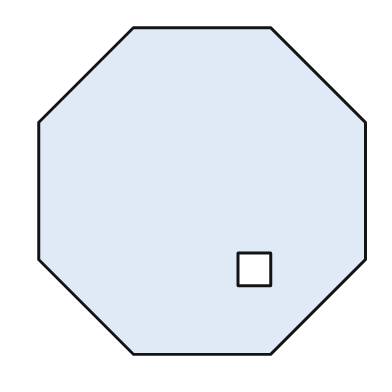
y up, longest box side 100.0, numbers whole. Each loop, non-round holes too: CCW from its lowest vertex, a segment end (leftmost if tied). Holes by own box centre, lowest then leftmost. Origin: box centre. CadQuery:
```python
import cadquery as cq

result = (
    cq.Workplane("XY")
    .moveTo(-21.0, -50.0)
    .lineTo(21.0, -50.0)
    .lineTo(50.0, -21.0)
    .lineTo(50.0, 21.0)
    .lineTo(21.0, 50.0)
    .lineTo(-21.0, 50.0)
    .lineTo(-50.0, 21.0)
    .lineTo(-50.0, -21.0)
    .close()
    .moveTo(11.0, -29.0)
    .lineTo(21.0, -29.0)
    .lineTo(21.0, -19.0)
    .lineTo(11.0, -19.0)
    .close()
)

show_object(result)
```